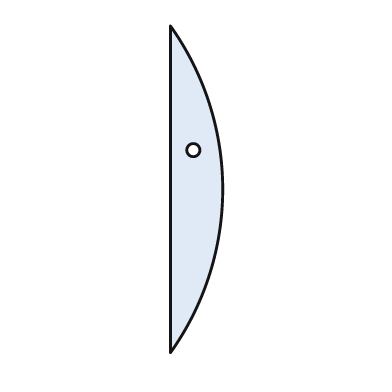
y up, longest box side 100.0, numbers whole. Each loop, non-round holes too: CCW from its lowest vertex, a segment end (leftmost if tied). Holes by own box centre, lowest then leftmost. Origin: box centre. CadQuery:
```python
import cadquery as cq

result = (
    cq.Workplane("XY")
    .moveTo(-8.0, -50.0)
    .threePointArc((8.0, 0.0), (-8.0, 50.0))
    .close()
    .moveTo(-1.0, 12.0)
    .circle(2.0)
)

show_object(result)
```